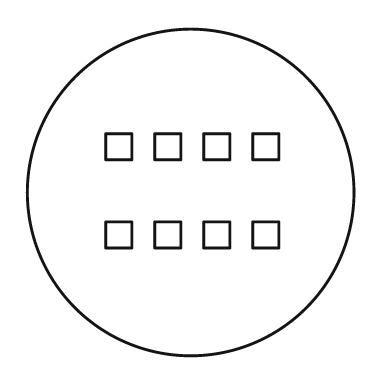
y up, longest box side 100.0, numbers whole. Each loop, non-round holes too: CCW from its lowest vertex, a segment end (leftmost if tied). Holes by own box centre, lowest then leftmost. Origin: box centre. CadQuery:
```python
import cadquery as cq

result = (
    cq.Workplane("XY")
    .moveTo(0.0, 0.0)
    .circle(50.0)
    .moveTo(-26.0, -17.0)
    .lineTo(-18.0, -17.0)
    .lineTo(-18.0, -9.0)
    .lineTo(-26.0, -9.0)
    .close()
    .moveTo(-11.0, -17.0)
    .lineTo(-3.0, -17.0)
    .lineTo(-3.0, -9.0)
    .lineTo(-11.0, -9.0)
    .close()
    .moveTo(4.0, -17.0)
    .lineTo(12.0, -17.0)
    .lineTo(12.0, -9.0)
    .lineTo(4.0, -9.0)
    .close()
    .moveTo(19.0, -17.0)
    .lineTo(27.0, -17.0)
    .lineTo(27.0, -9.0)
    .lineTo(19.0, -9.0)
    .close()
    .moveTo(-26.0, 10.0)
    .lineTo(-18.0, 10.0)
    .lineTo(-18.0, 18.0)
    .lineTo(-26.0, 18.0)
    .close()
    .moveTo(-11.0, 10.0)
    .lineTo(-3.0, 10.0)
    .lineTo(-3.0, 18.0)
    .lineTo(-11.0, 18.0)
    .close()
    .moveTo(4.0, 10.0)
    .lineTo(12.0, 10.0)
    .lineTo(12.0, 18.0)
    .lineTo(4.0, 18.0)
    .close()
    .moveTo(19.0, 10.0)
    .lineTo(27.0, 10.0)
    .lineTo(27.0, 18.0)
    .lineTo(19.0, 18.0)
    .close()
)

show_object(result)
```